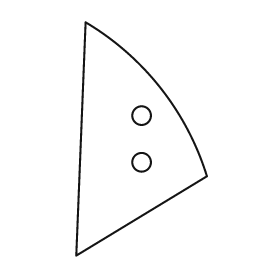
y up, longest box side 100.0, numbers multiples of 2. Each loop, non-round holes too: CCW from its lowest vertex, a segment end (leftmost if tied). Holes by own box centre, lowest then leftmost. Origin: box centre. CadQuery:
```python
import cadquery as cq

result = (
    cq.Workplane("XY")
    .moveTo(-28.0, -50.0)
    .lineTo(28.0, -16.0)
    .threePointArc((8.0, 22.0), (-24.0, 50.0))
    .close()
    .moveTo(0.0, -10.0)
    .circle(4.0)
    .moveTo(0.0, 10.0)
    .circle(4.0)
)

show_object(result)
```